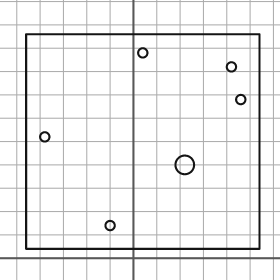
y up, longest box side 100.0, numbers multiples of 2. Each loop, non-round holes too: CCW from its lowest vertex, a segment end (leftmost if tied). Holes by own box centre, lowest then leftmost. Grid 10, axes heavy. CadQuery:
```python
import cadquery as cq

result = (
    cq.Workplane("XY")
    .moveTo(-46.0, 4.0)
    .lineTo(54.0, 4.0)
    .lineTo(54.0, 96.0)
    .lineTo(-46.0, 96.0)
    .close()
    .moveTo(-10.0, 14.0)
    .circle(2.0)
    .moveTo(22.0, 40.0)
    .circle(4.0)
    .moveTo(-38.0, 52.0)
    .circle(2.0)
    .moveTo(46.0, 68.0)
    .circle(2.0)
    .moveTo(42.0, 82.0)
    .circle(2.0)
    .moveTo(4.0, 88.0)
    .circle(2.0)
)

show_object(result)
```